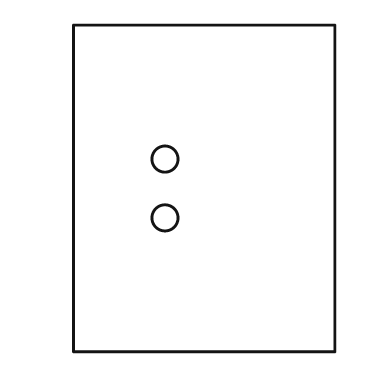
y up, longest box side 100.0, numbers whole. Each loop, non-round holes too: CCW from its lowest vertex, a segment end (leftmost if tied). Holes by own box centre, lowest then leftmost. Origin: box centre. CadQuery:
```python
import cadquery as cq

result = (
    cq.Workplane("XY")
    .moveTo(-40.0, -50.0)
    .lineTo(40.0, -50.0)
    .lineTo(40.0, 50.0)
    .lineTo(-40.0, 50.0)
    .close()
    .moveTo(-12.0, -9.0)
    .circle(4.0)
    .moveTo(-12.0, 9.0)
    .circle(4.0)
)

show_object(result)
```